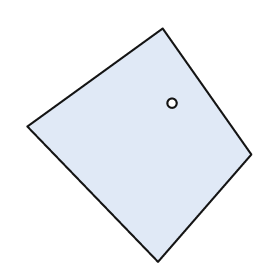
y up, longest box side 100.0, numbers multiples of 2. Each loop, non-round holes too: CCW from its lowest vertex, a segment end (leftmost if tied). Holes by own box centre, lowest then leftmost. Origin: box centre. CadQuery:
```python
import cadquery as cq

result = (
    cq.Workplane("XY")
    .moveTo(8.0, -50.0)
    .lineTo(48.0, -4.0)
    .lineTo(10.0, 50.0)
    .lineTo(-48.0, 8.0)
    .close()
    .moveTo(14.0, 18.0)
    .circle(2.0)
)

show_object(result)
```